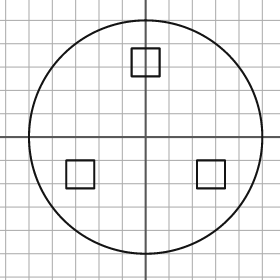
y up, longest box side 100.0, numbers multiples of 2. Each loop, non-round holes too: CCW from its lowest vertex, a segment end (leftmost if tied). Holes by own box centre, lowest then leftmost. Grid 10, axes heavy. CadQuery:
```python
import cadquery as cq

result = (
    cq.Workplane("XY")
    .moveTo(0.0, 0.0)
    .circle(50.0)
    .moveTo(-34.0, -22.0)
    .lineTo(-22.0, -22.0)
    .lineTo(-22.0, -10.0)
    .lineTo(-34.0, -10.0)
    .close()
    .moveTo(22.0, -22.0)
    .lineTo(34.0, -22.0)
    .lineTo(34.0, -10.0)
    .lineTo(22.0, -10.0)
    .close()
    .moveTo(-6.0, 26.0)
    .lineTo(6.0, 26.0)
    .lineTo(6.0, 38.0)
    .lineTo(-6.0, 38.0)
    .close()
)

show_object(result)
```